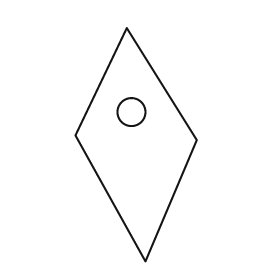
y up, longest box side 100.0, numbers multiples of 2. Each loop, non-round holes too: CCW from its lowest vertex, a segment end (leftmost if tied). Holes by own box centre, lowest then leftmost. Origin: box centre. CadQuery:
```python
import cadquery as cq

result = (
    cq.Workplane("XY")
    .moveTo(4.0, -50.0)
    .lineTo(26.0, 2.0)
    .lineTo(-4.0, 50.0)
    .lineTo(-26.0, 4.0)
    .close()
    .moveTo(-2.0, 14.0)
    .circle(6.0)
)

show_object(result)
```